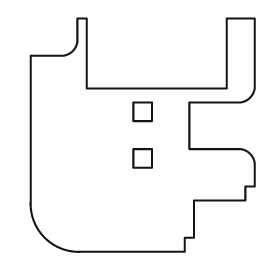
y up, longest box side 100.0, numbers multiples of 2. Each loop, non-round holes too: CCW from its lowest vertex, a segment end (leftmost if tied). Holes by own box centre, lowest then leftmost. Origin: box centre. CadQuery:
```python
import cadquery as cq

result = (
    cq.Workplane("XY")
    .moveTo(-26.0, -50.0)
    .lineTo(18.0, -50.0)
    .lineTo(18.0, -44.0)
    .lineTo(22.0, -44.0)
    .lineTo(22.0, -28.0)
    .lineTo(44.0, -28.0)
    .lineTo(44.0, -22.0)
    .lineTo(48.0, -22.0)
    .lineTo(48.0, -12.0)
    .threePointArc((46.0, -8.0), (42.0, -6.0))
    .lineTo(20.0, -6.0)
    .lineTo(20.0, 14.0)
    .lineTo(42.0, 14.0)
    .threePointArc((46.0, 16.0), (48.0, 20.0))
    .lineTo(48.0, 50.0)
    .lineTo(36.0, 50.0)
    .lineTo(36.0, 20.0)
    .lineTo(-24.0, 20.0)
    .lineTo(-24.0, 50.0)
    .lineTo(-28.0, 50.0)
    .lineTo(-28.0, 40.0)
    .threePointArc((-30.0, 36.0), (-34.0, 34.0))
    .lineTo(-48.0, 34.0)
    .lineTo(-48.0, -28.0)
    .threePointArc((-42.0, -44.0), (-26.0, -50.0))
    .close()
    .moveTo(-4.0, -14.0)
    .lineTo(4.0, -14.0)
    .lineTo(4.0, -6.0)
    .lineTo(-4.0, -6.0)
    .close()
    .moveTo(-4.0, 6.0)
    .lineTo(4.0, 6.0)
    .lineTo(4.0, 14.0)
    .lineTo(-4.0, 14.0)
    .close()
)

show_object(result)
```